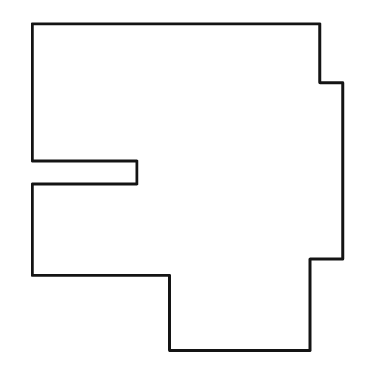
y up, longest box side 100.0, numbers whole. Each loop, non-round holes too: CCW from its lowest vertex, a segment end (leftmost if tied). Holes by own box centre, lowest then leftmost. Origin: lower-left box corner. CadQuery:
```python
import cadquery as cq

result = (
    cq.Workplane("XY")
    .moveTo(42.0, 0.0)
    .lineTo(85.0, 0.0)
    .lineTo(85.0, 28.0)
    .lineTo(95.0, 28.0)
    .lineTo(95.0, 82.0)
    .lineTo(88.0, 82.0)
    .lineTo(88.0, 100.0)
    .lineTo(0.0, 100.0)
    .lineTo(0.0, 58.0)
    .lineTo(32.0, 58.0)
    .lineTo(32.0, 51.0)
    .lineTo(0.0, 51.0)
    .lineTo(0.0, 23.0)
    .lineTo(42.0, 23.0)
    .close()
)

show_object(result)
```